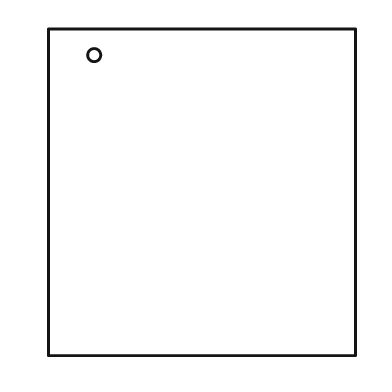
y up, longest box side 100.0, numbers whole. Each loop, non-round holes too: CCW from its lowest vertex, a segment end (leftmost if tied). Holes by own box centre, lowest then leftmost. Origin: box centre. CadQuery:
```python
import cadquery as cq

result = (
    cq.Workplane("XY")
    .moveTo(-47.0, -50.0)
    .lineTo(47.0, -50.0)
    .lineTo(47.0, 50.0)
    .lineTo(-47.0, 50.0)
    .close()
    .moveTo(-33.0, 42.0)
    .circle(2.0)
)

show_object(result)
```